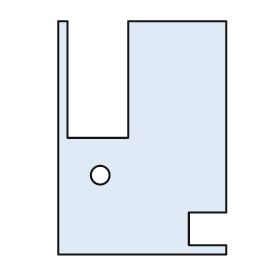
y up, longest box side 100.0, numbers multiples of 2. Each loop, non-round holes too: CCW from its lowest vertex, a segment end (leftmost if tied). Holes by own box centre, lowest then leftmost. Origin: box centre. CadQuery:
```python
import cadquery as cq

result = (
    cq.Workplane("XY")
    .moveTo(-36.0, -50.0)
    .lineTo(36.0, -50.0)
    .lineTo(36.0, -46.0)
    .lineTo(20.0, -46.0)
    .lineTo(20.0, -32.0)
    .lineTo(36.0, -32.0)
    .lineTo(36.0, 50.0)
    .lineTo(-6.0, 50.0)
    .lineTo(-6.0, 0.0)
    .lineTo(-32.0, 0.0)
    .lineTo(-32.0, 50.0)
    .lineTo(-36.0, 50.0)
    .close()
    .moveTo(-18.0, -16.0)
    .circle(4.0)
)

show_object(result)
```